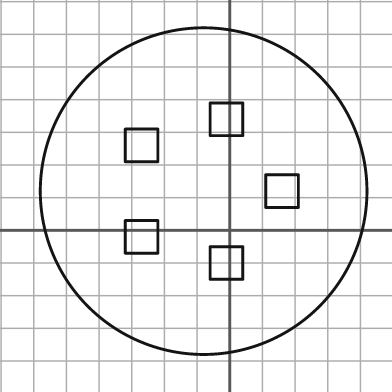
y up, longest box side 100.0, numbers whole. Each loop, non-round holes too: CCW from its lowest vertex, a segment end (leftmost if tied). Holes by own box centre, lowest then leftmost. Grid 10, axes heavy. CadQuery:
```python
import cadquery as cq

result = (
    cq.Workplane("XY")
    .moveTo(-8.0, 12.0)
    .circle(50.0)
    .moveTo(-6.0, -15.0)
    .lineTo(4.0, -15.0)
    .lineTo(4.0, -5.0)
    .lineTo(-6.0, -5.0)
    .close()
    .moveTo(-32.0, -7.0)
    .lineTo(-22.0, -7.0)
    .lineTo(-22.0, 3.0)
    .lineTo(-32.0, 3.0)
    .close()
    .moveTo(11.0, 7.0)
    .lineTo(21.0, 7.0)
    .lineTo(21.0, 17.0)
    .lineTo(11.0, 17.0)
    .close()
    .moveTo(-32.0, 21.0)
    .lineTo(-22.0, 21.0)
    .lineTo(-22.0, 31.0)
    .lineTo(-32.0, 31.0)
    .close()
    .moveTo(-6.0, 29.0)
    .lineTo(4.0, 29.0)
    .lineTo(4.0, 39.0)
    .lineTo(-6.0, 39.0)
    .close()
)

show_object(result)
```